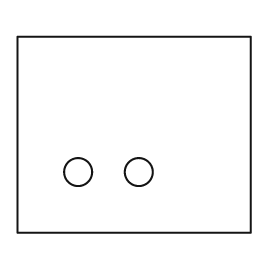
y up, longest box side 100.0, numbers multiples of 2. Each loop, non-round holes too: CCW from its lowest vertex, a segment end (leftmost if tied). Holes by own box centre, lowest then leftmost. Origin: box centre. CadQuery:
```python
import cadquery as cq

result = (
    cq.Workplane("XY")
    .moveTo(-50.0, -42.0)
    .lineTo(50.0, -42.0)
    .lineTo(50.0, 42.0)
    .lineTo(-50.0, 42.0)
    .close()
    .moveTo(-24.0, -16.0)
    .circle(6.0)
    .moveTo(2.0, -16.0)
    .circle(6.0)
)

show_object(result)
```